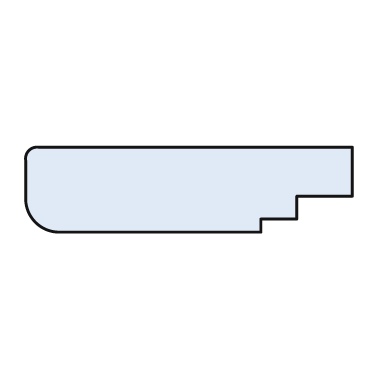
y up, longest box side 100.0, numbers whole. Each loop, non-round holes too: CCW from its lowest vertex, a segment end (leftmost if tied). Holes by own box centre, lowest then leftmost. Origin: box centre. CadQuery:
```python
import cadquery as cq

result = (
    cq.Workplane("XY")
    .moveTo(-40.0, -13.0)
    .lineTo(22.0, -13.0)
    .lineTo(22.0, -9.0)
    .lineTo(33.0, -9.0)
    .lineTo(33.0, -2.0)
    .lineTo(50.0, -2.0)
    .lineTo(50.0, 13.0)
    .lineTo(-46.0, 13.0)
    .threePointArc((-49.0, 12.0), (-50.0, 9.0))
    .lineTo(-50.0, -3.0)
    .threePointArc((-47.0, -10.0), (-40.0, -13.0))
    .close()
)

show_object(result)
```